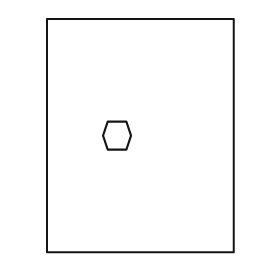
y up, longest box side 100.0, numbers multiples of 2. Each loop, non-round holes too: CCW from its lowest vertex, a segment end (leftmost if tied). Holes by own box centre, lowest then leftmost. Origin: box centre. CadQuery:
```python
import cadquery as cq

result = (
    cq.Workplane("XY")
    .moveTo(-40.0, -50.0)
    .lineTo(40.0, -50.0)
    .lineTo(40.0, 50.0)
    .lineTo(-40.0, 50.0)
    .close()
    .moveTo(-14.0, -6.0)
    .lineTo(-6.0, -6.0)
    .lineTo(-4.0, 0.0)
    .lineTo(-6.0, 6.0)
    .lineTo(-14.0, 6.0)
    .lineTo(-16.0, 0.0)
    .close()
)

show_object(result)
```